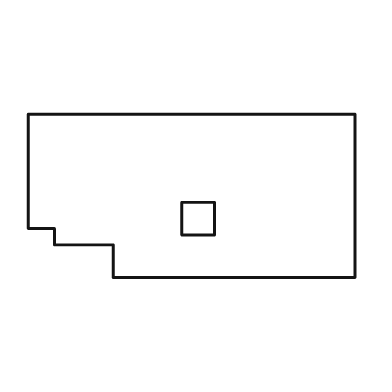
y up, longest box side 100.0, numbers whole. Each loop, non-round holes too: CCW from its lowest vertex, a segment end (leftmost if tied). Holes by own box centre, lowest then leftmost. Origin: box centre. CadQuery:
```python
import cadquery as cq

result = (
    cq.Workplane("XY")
    .moveTo(-24.0, -25.0)
    .lineTo(50.0, -25.0)
    .lineTo(50.0, 25.0)
    .lineTo(-50.0, 25.0)
    .lineTo(-50.0, -10.0)
    .lineTo(-42.0, -10.0)
    .lineTo(-42.0, -15.0)
    .lineTo(-24.0, -15.0)
    .close()
    .moveTo(-3.0, -12.0)
    .lineTo(7.0, -12.0)
    .lineTo(7.0, -2.0)
    .lineTo(-3.0, -2.0)
    .close()
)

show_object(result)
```